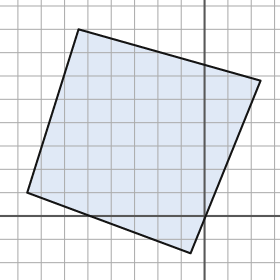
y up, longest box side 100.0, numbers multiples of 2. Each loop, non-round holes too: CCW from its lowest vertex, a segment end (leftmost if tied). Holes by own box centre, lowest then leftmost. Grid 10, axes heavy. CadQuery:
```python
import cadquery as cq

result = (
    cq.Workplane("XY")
    .moveTo(-6.0, -16.0)
    .lineTo(24.0, 58.0)
    .lineTo(-54.0, 80.0)
    .lineTo(-76.0, 10.0)
    .close()
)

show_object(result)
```